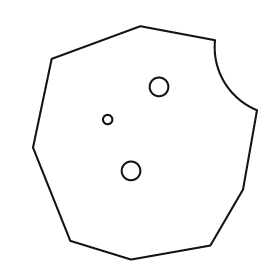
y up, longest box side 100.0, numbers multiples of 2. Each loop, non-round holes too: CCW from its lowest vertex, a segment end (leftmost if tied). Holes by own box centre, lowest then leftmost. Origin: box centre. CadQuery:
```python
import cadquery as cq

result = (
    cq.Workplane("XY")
    .moveTo(-6.0, -50.0)
    .lineTo(28.0, -44.0)
    .lineTo(42.0, -20.0)
    .lineTo(48.0, 14.0)
    .threePointArc((34.0, 26.0), (30.0, 44.0))
    .lineTo(-2.0, 50.0)
    .lineTo(-40.0, 36.0)
    .lineTo(-48.0, -2.0)
    .lineTo(-32.0, -42.0)
    .close()
    .moveTo(-6.0, -12.0)
    .circle(4.0)
    .moveTo(-16.0, 10.0)
    .circle(2.0)
    .moveTo(6.0, 24.0)
    .circle(4.0)
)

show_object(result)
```